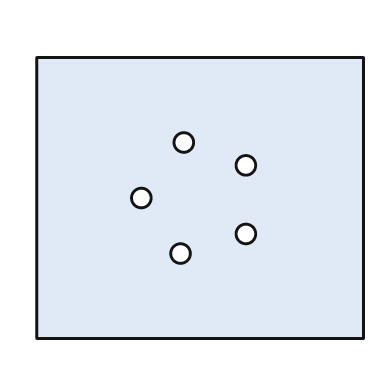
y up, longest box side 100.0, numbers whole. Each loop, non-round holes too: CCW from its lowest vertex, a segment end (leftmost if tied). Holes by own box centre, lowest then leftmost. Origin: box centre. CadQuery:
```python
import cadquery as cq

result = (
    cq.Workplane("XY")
    .moveTo(-50.0, -43.0)
    .lineTo(50.0, -43.0)
    .lineTo(50.0, 43.0)
    .lineTo(-50.0, 43.0)
    .close()
    .moveTo(-6.0, -17.0)
    .circle(3.0)
    .moveTo(14.0, -11.0)
    .circle(3.0)
    .moveTo(-18.0, 0.0)
    .circle(3.0)
    .moveTo(14.0, 10.0)
    .circle(3.0)
    .moveTo(-5.0, 17.0)
    .circle(3.0)
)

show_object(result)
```